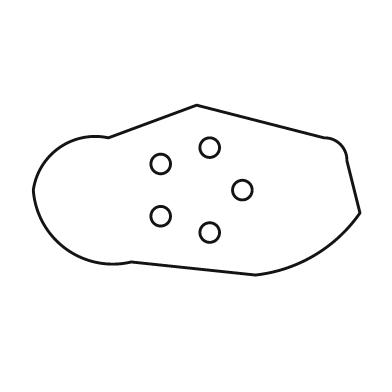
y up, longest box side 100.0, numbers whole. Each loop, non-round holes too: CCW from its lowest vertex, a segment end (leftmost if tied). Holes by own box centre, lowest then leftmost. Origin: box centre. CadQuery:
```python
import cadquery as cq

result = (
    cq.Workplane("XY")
    .moveTo(18.0, -26.0)
    .threePointArc((36.0, -20.0), (50.0, -7.0))
    .lineTo(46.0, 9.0)
    .threePointArc((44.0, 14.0), (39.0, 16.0))
    .lineTo(0.0, 26.0)
    .lineTo(-27.0, 16.0)
    .threePointArc((-42.0, 13.0), (-50.0, 0.0))
    .threePointArc((-40.0, -18.0), (-20.0, -22.0))
    .close()
    .moveTo(4.0, -13.0)
    .circle(3.0)
    .moveTo(-11.0, -8.0)
    .circle(3.0)
    .moveTo(14.0, 0.0)
    .circle(3.0)
    .moveTo(-11.0, 8.0)
    .circle(3.0)
    .moveTo(4.0, 13.0)
    .circle(3.0)
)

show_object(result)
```